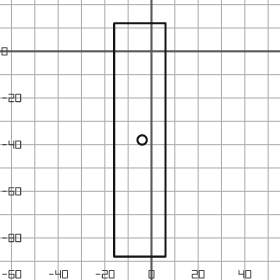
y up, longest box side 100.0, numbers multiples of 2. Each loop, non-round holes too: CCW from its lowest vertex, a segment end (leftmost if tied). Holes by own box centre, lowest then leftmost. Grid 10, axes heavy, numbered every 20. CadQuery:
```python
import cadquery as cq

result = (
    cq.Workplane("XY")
    .moveTo(-16.0, -88.0)
    .lineTo(6.0, -88.0)
    .lineTo(6.0, 12.0)
    .lineTo(-16.0, 12.0)
    .close()
    .moveTo(-4.0, -38.0)
    .circle(2.0)
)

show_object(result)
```